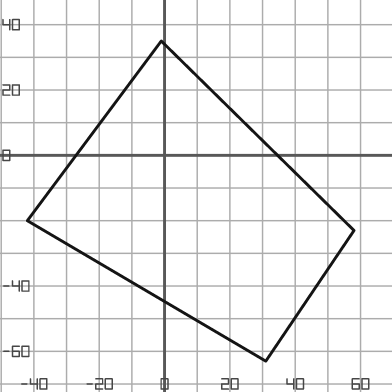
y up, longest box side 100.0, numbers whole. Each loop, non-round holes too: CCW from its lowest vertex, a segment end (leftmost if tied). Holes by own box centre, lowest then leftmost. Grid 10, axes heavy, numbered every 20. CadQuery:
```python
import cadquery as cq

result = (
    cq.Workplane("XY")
    .moveTo(31.0, -63.0)
    .lineTo(58.0, -23.0)
    .lineTo(-1.0, 35.0)
    .lineTo(-42.0, -20.0)
    .close()
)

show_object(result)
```